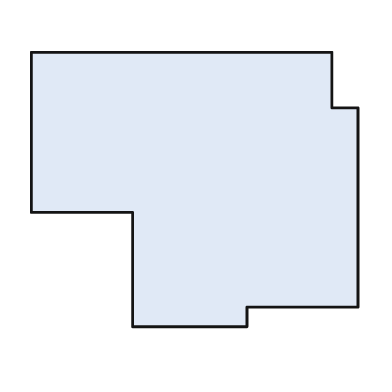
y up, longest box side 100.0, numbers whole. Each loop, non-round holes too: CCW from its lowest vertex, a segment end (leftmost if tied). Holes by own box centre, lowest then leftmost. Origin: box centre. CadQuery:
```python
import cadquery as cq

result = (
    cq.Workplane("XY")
    .moveTo(-19.0, -42.0)
    .lineTo(16.0, -42.0)
    .lineTo(16.0, -36.0)
    .lineTo(50.0, -36.0)
    .lineTo(50.0, 25.0)
    .lineTo(42.0, 25.0)
    .lineTo(42.0, 42.0)
    .lineTo(-50.0, 42.0)
    .lineTo(-50.0, -7.0)
    .lineTo(-19.0, -7.0)
    .close()
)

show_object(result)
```